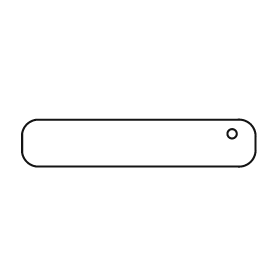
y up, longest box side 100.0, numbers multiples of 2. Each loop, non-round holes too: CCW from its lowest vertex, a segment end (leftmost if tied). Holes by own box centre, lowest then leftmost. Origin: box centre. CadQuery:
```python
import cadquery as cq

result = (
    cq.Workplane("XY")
    .moveTo(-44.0, -10.0)
    .lineTo(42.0, -10.0)
    .threePointArc((48.0, -8.0), (50.0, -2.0))
    .lineTo(50.0, 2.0)
    .threePointArc((48.0, 8.0), (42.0, 10.0))
    .lineTo(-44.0, 10.0)
    .threePointArc((-48.0, 8.0), (-50.0, 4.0))
    .lineTo(-50.0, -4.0)
    .threePointArc((-48.0, -8.0), (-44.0, -10.0))
    .close()
    .moveTo(40.0, 4.0)
    .circle(2.0)
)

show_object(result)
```